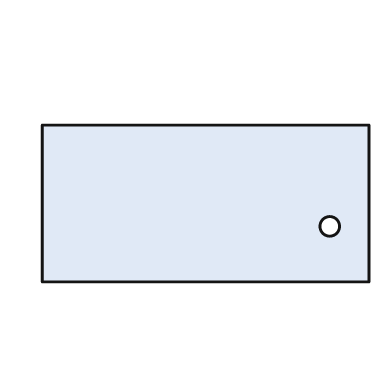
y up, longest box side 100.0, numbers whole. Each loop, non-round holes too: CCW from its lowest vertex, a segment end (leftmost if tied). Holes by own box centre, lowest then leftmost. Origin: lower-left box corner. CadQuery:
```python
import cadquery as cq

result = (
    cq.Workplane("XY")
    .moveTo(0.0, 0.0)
    .lineTo(100.0, 0.0)
    .lineTo(100.0, 48.0)
    .lineTo(0.0, 48.0)
    .close()
    .moveTo(88.0, 17.0)
    .circle(3.0)
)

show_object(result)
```